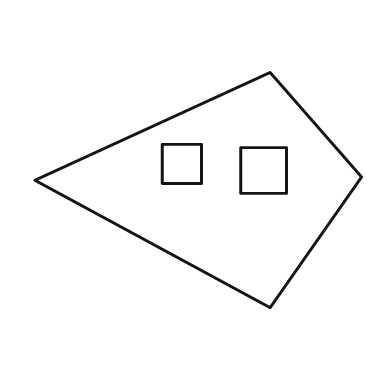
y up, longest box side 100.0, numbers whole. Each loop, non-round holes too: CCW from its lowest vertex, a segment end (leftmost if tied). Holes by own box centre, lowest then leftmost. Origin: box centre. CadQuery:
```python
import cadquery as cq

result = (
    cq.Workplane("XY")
    .moveTo(22.0, -36.0)
    .lineTo(50.0, 4.0)
    .lineTo(22.0, 36.0)
    .lineTo(-50.0, 3.0)
    .close()
    .moveTo(13.0, -1.0)
    .lineTo(27.0, -1.0)
    .lineTo(27.0, 13.0)
    .lineTo(13.0, 13.0)
    .close()
    .moveTo(-11.0, 2.0)
    .lineTo(1.0, 2.0)
    .lineTo(1.0, 14.0)
    .lineTo(-11.0, 14.0)
    .close()
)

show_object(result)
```